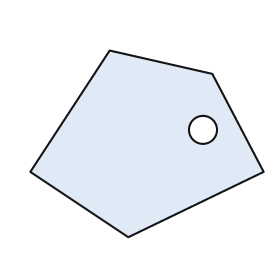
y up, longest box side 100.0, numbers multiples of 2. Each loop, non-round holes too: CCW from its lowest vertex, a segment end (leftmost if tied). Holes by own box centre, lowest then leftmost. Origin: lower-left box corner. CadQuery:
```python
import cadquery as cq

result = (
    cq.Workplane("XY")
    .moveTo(42.0, 0.0)
    .lineTo(100.0, 28.0)
    .lineTo(78.0, 70.0)
    .lineTo(34.0, 80.0)
    .lineTo(0.0, 28.0)
    .close()
    .moveTo(74.0, 46.0)
    .circle(6.0)
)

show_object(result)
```